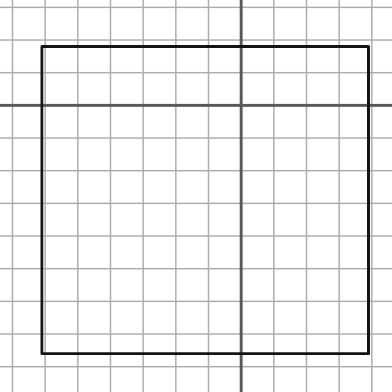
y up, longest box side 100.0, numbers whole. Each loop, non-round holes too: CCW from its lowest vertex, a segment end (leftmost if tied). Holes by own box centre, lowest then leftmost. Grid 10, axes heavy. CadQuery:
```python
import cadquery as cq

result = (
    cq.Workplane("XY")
    .moveTo(-61.0, -76.0)
    .lineTo(39.0, -76.0)
    .lineTo(39.0, 18.0)
    .lineTo(-61.0, 18.0)
    .close()
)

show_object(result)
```